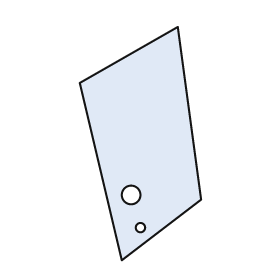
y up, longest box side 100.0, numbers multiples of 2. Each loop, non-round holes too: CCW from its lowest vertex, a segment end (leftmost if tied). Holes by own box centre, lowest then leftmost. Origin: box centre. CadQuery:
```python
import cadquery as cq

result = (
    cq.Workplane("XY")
    .moveTo(-8.0, -50.0)
    .lineTo(26.0, -24.0)
    .lineTo(16.0, 50.0)
    .lineTo(-26.0, 26.0)
    .close()
    .moveTo(0.0, -36.0)
    .circle(2.0)
    .moveTo(-4.0, -22.0)
    .circle(4.0)
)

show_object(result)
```